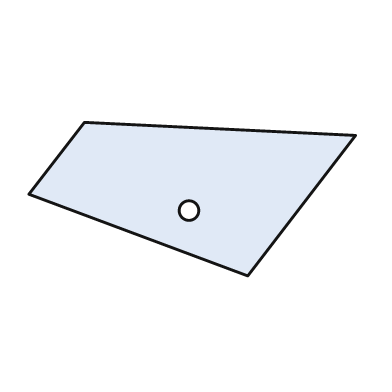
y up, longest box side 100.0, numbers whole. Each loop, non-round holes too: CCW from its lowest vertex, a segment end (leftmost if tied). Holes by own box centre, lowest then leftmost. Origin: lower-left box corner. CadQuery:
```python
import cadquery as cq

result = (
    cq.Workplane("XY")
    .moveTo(67.0, 0.0)
    .lineTo(100.0, 43.0)
    .lineTo(17.0, 47.0)
    .lineTo(0.0, 25.0)
    .close()
    .moveTo(49.0, 20.0)
    .circle(3.0)
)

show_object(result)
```